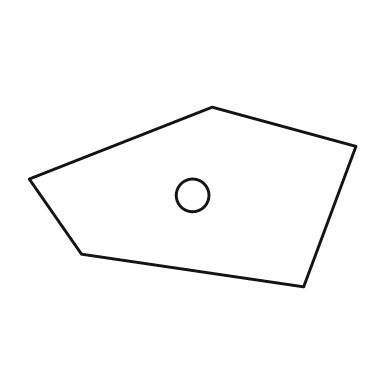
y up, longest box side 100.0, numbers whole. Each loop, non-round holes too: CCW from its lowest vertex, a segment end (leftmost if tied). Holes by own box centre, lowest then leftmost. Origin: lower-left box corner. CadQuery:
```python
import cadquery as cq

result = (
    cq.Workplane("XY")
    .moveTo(84.0, 0.0)
    .lineTo(100.0, 43.0)
    .lineTo(56.0, 55.0)
    .lineTo(0.0, 33.0)
    .lineTo(16.0, 10.0)
    .close()
    .moveTo(50.0, 28.0)
    .circle(5.0)
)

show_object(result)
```